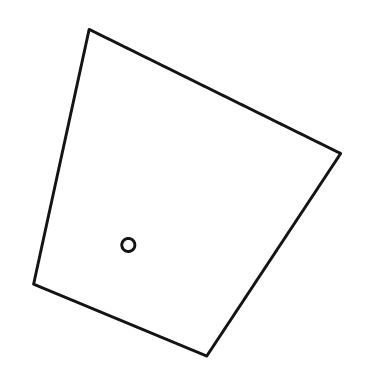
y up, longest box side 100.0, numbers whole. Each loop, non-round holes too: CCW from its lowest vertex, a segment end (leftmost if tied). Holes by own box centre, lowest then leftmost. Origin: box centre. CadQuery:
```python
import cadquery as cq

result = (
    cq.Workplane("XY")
    .moveTo(6.0, -50.0)
    .lineTo(47.0, 12.0)
    .lineTo(-30.0, 50.0)
    .lineTo(-47.0, -28.0)
    .close()
    .moveTo(-18.0, -16.0)
    .circle(2.0)
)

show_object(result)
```